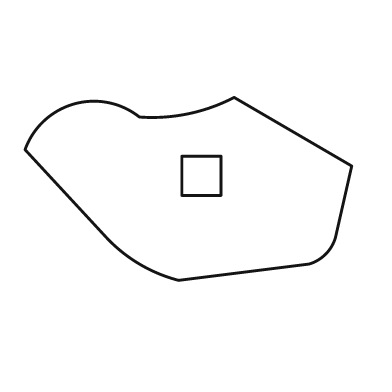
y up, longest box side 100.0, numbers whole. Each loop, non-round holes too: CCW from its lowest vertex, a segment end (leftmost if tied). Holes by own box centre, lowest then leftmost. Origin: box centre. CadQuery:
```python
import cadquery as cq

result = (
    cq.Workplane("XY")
    .moveTo(-3.0, -28.0)
    .lineTo(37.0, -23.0)
    .threePointArc((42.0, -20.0), (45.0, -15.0))
    .lineTo(50.0, 7.0)
    .lineTo(14.0, 28.0)
    .threePointArc((0.0, 23.0), (-15.0, 22.0))
    .threePointArc((-35.0, 26.0), (-50.0, 12.0))
    .lineTo(-25.0, -15.0)
    .threePointArc((-15.0, -23.0), (-3.0, -28.0))
    .close()
    .moveTo(-2.0, -2.0)
    .lineTo(10.0, -2.0)
    .lineTo(10.0, 10.0)
    .lineTo(-2.0, 10.0)
    .close()
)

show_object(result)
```